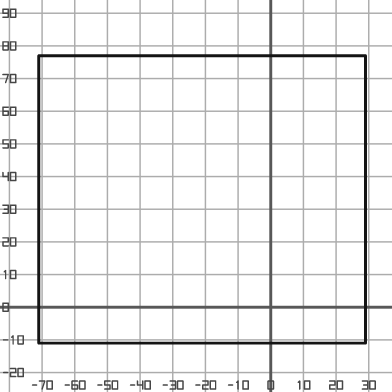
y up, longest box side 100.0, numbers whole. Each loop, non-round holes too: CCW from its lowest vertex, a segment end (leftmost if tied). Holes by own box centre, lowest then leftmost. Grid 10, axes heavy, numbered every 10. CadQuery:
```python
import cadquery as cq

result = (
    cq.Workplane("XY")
    .moveTo(-71.0, -11.0)
    .lineTo(29.0, -11.0)
    .lineTo(29.0, 77.0)
    .lineTo(-71.0, 77.0)
    .close()
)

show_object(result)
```